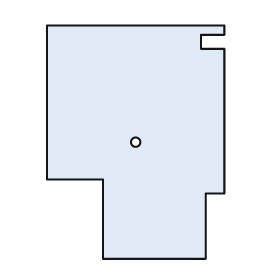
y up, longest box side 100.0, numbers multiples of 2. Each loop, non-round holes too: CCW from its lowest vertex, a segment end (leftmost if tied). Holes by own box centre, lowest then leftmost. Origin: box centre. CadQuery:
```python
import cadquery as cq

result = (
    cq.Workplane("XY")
    .moveTo(-14.0, -50.0)
    .lineTo(30.0, -50.0)
    .lineTo(30.0, -22.0)
    .lineTo(38.0, -22.0)
    .lineTo(38.0, 40.0)
    .lineTo(28.0, 40.0)
    .lineTo(28.0, 46.0)
    .lineTo(38.0, 46.0)
    .lineTo(38.0, 50.0)
    .lineTo(-38.0, 50.0)
    .lineTo(-38.0, -16.0)
    .lineTo(-14.0, -16.0)
    .close()
    .moveTo(0.0, 0.0)
    .circle(2.0)
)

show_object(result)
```